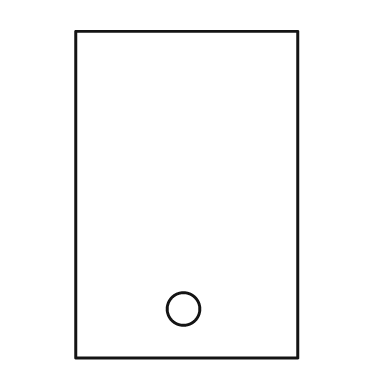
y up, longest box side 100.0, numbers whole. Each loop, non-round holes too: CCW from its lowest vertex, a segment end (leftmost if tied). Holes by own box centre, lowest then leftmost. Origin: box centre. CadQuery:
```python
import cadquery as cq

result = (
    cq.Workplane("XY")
    .moveTo(-34.0, -50.0)
    .lineTo(34.0, -50.0)
    .lineTo(34.0, 50.0)
    .lineTo(-34.0, 50.0)
    .close()
    .moveTo(-1.0, -35.0)
    .circle(5.0)
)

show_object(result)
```